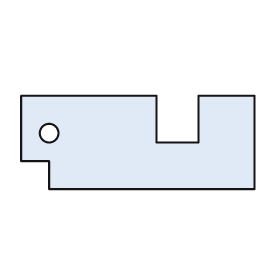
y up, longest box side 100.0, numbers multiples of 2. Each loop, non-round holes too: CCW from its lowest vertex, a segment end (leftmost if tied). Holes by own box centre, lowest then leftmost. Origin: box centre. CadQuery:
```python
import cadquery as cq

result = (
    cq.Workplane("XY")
    .moveTo(-38.0, -20.0)
    .lineTo(50.0, -20.0)
    .lineTo(50.0, 20.0)
    .lineTo(26.0, 20.0)
    .lineTo(26.0, 0.0)
    .lineTo(8.0, 0.0)
    .lineTo(8.0, 20.0)
    .lineTo(-50.0, 20.0)
    .lineTo(-50.0, -8.0)
    .lineTo(-38.0, -8.0)
    .close()
    .moveTo(-38.0, 4.0)
    .circle(4.0)
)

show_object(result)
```